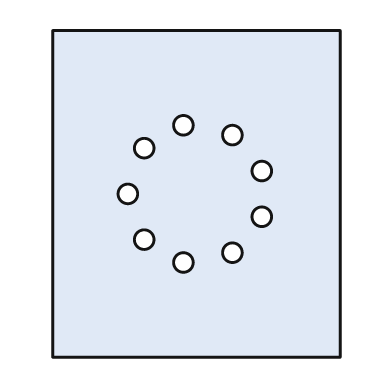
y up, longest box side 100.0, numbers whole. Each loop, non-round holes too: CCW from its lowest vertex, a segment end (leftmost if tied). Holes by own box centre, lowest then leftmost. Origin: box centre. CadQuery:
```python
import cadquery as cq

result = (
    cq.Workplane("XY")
    .moveTo(-44.0, -50.0)
    .lineTo(44.0, -50.0)
    .lineTo(44.0, 50.0)
    .lineTo(-44.0, 50.0)
    .close()
    .moveTo(-4.0, -21.0)
    .circle(3.0)
    .moveTo(11.0, -18.0)
    .circle(3.0)
    .moveTo(-16.0, -14.0)
    .circle(3.0)
    .moveTo(20.0, -7.0)
    .circle(3.0)
    .moveTo(-21.0, 0.0)
    .circle(3.0)
    .moveTo(20.0, 7.0)
    .circle(3.0)
    .moveTo(-16.0, 14.0)
    .circle(3.0)
    .moveTo(11.0, 18.0)
    .circle(3.0)
    .moveTo(-4.0, 21.0)
    .circle(3.0)
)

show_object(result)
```